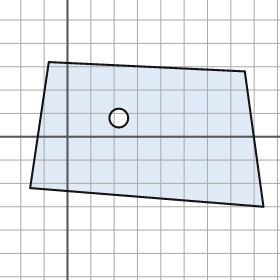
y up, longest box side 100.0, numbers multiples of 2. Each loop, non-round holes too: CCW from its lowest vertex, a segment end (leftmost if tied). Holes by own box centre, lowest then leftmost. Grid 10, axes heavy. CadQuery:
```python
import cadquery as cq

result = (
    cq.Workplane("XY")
    .moveTo(84.0, -30.0)
    .lineTo(76.0, 28.0)
    .lineTo(-8.0, 32.0)
    .lineTo(-16.0, -22.0)
    .close()
    .moveTo(22.0, 8.0)
    .circle(4.0)
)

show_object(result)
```